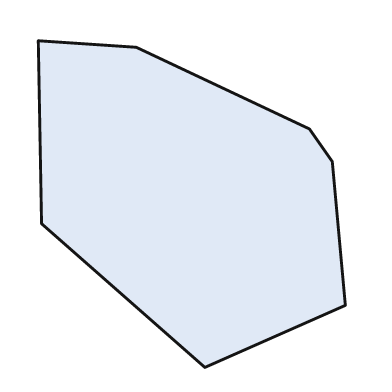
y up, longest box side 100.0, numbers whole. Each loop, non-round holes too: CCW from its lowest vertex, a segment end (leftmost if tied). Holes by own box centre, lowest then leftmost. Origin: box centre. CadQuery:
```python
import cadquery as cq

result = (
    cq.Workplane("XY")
    .moveTo(4.0, -50.0)
    .lineTo(47.0, -31.0)
    .lineTo(43.0, 13.0)
    .lineTo(36.0, 23.0)
    .lineTo(-17.0, 48.0)
    .lineTo(-47.0, 50.0)
    .lineTo(-46.0, -6.0)
    .close()
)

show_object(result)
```